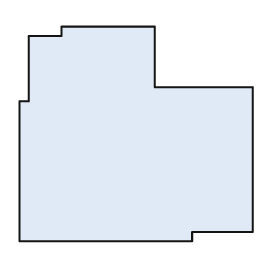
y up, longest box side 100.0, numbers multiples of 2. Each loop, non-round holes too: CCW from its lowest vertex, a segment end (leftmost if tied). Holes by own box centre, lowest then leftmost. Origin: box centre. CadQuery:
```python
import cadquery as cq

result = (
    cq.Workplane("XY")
    .moveTo(-50.0, -46.0)
    .lineTo(24.0, -46.0)
    .lineTo(24.0, -42.0)
    .lineTo(50.0, -42.0)
    .lineTo(50.0, 20.0)
    .lineTo(8.0, 20.0)
    .lineTo(8.0, 46.0)
    .lineTo(-32.0, 46.0)
    .lineTo(-32.0, 42.0)
    .lineTo(-46.0, 42.0)
    .lineTo(-46.0, 14.0)
    .lineTo(-50.0, 14.0)
    .close()
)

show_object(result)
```